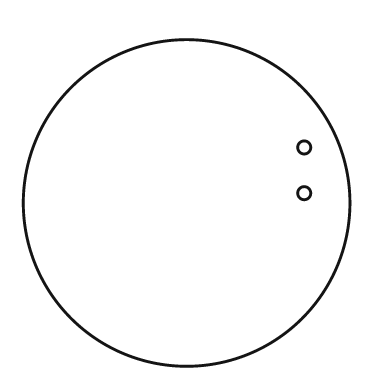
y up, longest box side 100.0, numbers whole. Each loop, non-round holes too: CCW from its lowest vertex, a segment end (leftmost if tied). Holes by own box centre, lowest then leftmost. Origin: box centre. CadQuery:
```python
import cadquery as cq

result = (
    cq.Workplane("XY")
    .moveTo(0.0, 0.0)
    .circle(50.0)
    .moveTo(36.0, 3.0)
    .circle(2.0)
    .moveTo(36.0, 17.0)
    .circle(2.0)
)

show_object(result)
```